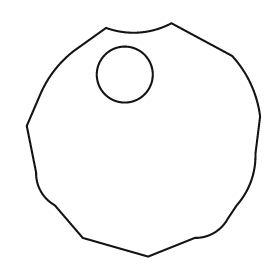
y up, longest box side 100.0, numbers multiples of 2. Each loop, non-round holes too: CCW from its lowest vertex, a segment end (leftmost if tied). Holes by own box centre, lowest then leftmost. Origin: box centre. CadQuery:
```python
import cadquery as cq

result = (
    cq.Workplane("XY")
    .moveTo(2.0, -50.0)
    .lineTo(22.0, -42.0)
    .threePointArc((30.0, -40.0), (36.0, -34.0))
    .lineTo(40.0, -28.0)
    .threePointArc((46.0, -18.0), (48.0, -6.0))
    .lineTo(50.0, 10.0)
    .threePointArc((46.0, 24.0), (38.0, 36.0))
    .lineTo(12.0, 50.0)
    .threePointArc((-2.0, 46.0), (-16.0, 48.0))
    .lineTo(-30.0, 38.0)
    .threePointArc((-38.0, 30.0), (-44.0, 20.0))
    .lineTo(-50.0, 6.0)
    .lineTo(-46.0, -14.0)
    .threePointArc((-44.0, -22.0), (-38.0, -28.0))
    .lineTo(-26.0, -42.0)
    .close()
    .moveTo(-8.0, 28.0)
    .circle(12.0)
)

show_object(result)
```